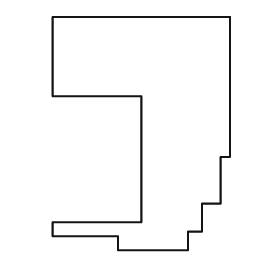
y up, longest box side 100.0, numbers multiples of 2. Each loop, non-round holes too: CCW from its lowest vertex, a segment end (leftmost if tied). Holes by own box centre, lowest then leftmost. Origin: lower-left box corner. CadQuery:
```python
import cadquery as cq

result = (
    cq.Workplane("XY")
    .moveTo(28.0, 0.0)
    .lineTo(58.0, 0.0)
    .lineTo(58.0, 8.0)
    .lineTo(64.0, 8.0)
    .lineTo(64.0, 20.0)
    .lineTo(72.0, 20.0)
    .lineTo(72.0, 40.0)
    .lineTo(76.0, 40.0)
    .lineTo(76.0, 100.0)
    .lineTo(0.0, 100.0)
    .lineTo(0.0, 66.0)
    .lineTo(38.0, 66.0)
    .lineTo(38.0, 12.0)
    .lineTo(0.0, 12.0)
    .lineTo(0.0, 6.0)
    .lineTo(28.0, 6.0)
    .close()
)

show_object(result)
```